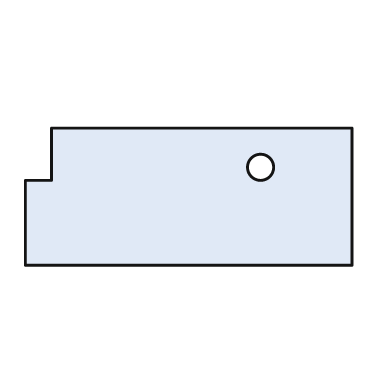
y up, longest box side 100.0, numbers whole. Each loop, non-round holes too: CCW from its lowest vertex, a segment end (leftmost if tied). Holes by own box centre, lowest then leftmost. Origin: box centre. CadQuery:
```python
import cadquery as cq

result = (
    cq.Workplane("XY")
    .moveTo(-50.0, -21.0)
    .lineTo(50.0, -21.0)
    .lineTo(50.0, 21.0)
    .lineTo(-42.0, 21.0)
    .lineTo(-42.0, 5.0)
    .lineTo(-50.0, 5.0)
    .close()
    .moveTo(22.0, 9.0)
    .circle(4.0)
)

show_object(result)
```